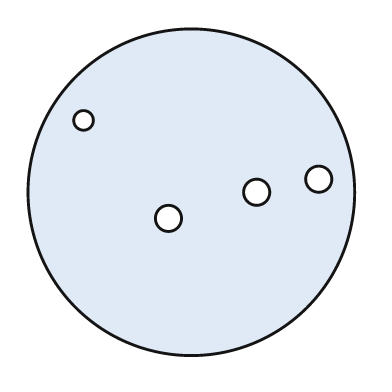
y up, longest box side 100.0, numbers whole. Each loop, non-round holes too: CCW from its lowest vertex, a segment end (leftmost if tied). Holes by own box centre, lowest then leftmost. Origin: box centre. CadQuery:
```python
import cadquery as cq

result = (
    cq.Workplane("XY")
    .moveTo(0.0, 0.0)
    .circle(50.0)
    .moveTo(-7.0, -8.0)
    .circle(4.0)
    .moveTo(20.0, 0.0)
    .circle(4.0)
    .moveTo(39.0, 4.0)
    .circle(4.0)
    .moveTo(-33.0, 22.0)
    .circle(3.0)
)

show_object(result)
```